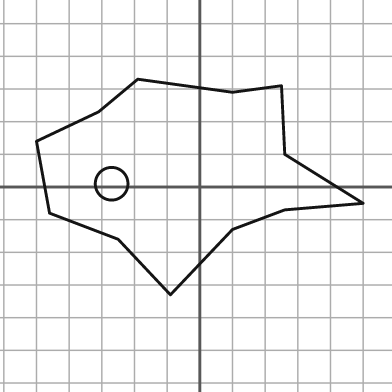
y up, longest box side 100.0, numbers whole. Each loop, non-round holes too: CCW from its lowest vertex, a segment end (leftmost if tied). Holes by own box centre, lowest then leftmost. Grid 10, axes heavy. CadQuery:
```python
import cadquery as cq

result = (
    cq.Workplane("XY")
    .moveTo(-9.0, -33.0)
    .lineTo(10.0, -13.0)
    .lineTo(26.0, -7.0)
    .lineTo(50.0, -5.0)
    .lineTo(26.0, 10.0)
    .lineTo(25.0, 31.0)
    .lineTo(10.0, 29.0)
    .lineTo(-19.0, 33.0)
    .lineTo(-31.0, 23.0)
    .lineTo(-50.0, 14.0)
    .lineTo(-46.0, -8.0)
    .lineTo(-25.0, -16.0)
    .close()
    .moveTo(-27.0, 1.0)
    .circle(5.0)
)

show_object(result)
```